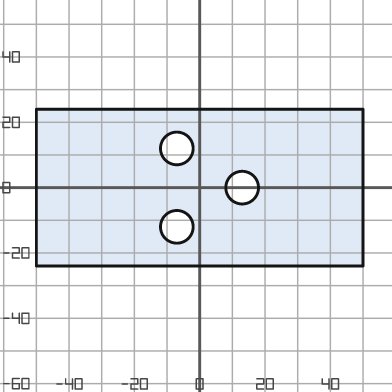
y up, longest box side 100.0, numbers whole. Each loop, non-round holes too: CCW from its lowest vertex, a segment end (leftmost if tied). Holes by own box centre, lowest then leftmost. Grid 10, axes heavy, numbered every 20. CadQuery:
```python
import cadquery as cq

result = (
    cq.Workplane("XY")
    .moveTo(-50.0, -24.0)
    .lineTo(50.0, -24.0)
    .lineTo(50.0, 24.0)
    .lineTo(-50.0, 24.0)
    .close()
    .moveTo(-7.0, -12.0)
    .circle(5.0)
    .moveTo(13.0, 0.0)
    .circle(5.0)
    .moveTo(-7.0, 12.0)
    .circle(5.0)
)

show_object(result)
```